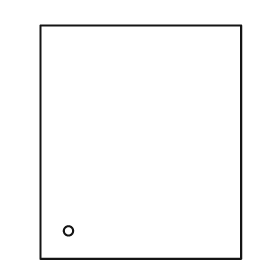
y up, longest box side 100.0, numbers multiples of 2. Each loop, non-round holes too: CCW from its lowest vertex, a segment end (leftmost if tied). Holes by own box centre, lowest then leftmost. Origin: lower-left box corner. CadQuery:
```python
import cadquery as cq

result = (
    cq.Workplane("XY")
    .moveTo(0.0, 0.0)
    .lineTo(86.0, 0.0)
    .lineTo(86.0, 100.0)
    .lineTo(0.0, 100.0)
    .close()
    .moveTo(12.0, 12.0)
    .circle(2.0)
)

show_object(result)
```